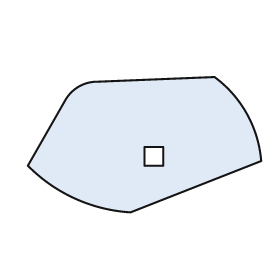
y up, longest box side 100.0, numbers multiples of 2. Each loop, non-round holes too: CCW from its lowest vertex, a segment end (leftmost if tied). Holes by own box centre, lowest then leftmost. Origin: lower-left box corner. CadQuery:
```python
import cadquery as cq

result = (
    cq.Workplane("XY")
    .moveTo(44.0, 0.0)
    .lineTo(100.0, 22.0)
    .threePointArc((94.0, 42.0), (80.0, 58.0))
    .lineTo(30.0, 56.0)
    .threePointArc((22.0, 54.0), (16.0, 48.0))
    .lineTo(0.0, 20.0)
    .threePointArc((20.0, 6.0), (44.0, 0.0))
    .close()
    .moveTo(50.0, 20.0)
    .lineTo(58.0, 20.0)
    .lineTo(58.0, 28.0)
    .lineTo(50.0, 28.0)
    .close()
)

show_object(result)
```